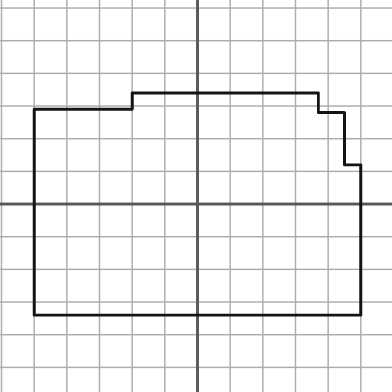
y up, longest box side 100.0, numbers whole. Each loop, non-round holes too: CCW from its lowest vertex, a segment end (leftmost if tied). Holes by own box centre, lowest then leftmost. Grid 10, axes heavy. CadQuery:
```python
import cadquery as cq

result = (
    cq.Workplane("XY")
    .moveTo(-50.0, -34.0)
    .lineTo(50.0, -34.0)
    .lineTo(50.0, 12.0)
    .lineTo(45.0, 12.0)
    .lineTo(45.0, 28.0)
    .lineTo(37.0, 28.0)
    .lineTo(37.0, 34.0)
    .lineTo(-20.0, 34.0)
    .lineTo(-20.0, 29.0)
    .lineTo(-50.0, 29.0)
    .close()
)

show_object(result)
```